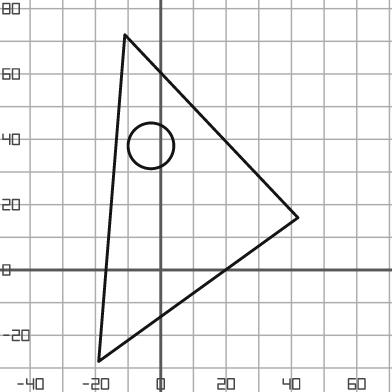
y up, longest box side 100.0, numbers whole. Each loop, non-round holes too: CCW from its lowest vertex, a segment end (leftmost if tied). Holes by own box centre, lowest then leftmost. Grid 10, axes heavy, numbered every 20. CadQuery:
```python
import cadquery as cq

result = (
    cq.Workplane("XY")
    .moveTo(-19.0, -28.0)
    .lineTo(42.0, 16.0)
    .lineTo(-11.0, 72.0)
    .close()
    .moveTo(-3.0, 38.0)
    .circle(7.0)
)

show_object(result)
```